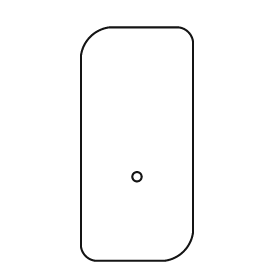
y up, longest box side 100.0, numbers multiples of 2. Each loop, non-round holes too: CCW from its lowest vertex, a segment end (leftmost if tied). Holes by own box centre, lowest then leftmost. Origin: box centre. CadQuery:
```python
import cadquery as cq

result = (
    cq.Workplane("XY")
    .moveTo(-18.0, -50.0)
    .lineTo(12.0, -50.0)
    .threePointArc((20.0, -46.0), (24.0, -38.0))
    .lineTo(24.0, 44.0)
    .threePointArc((22.0, 48.0), (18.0, 50.0))
    .lineTo(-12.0, 50.0)
    .threePointArc((-20.0, 46.0), (-24.0, 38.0))
    .lineTo(-24.0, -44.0)
    .threePointArc((-22.0, -48.0), (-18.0, -50.0))
    .close()
    .moveTo(0.0, -14.0)
    .circle(2.0)
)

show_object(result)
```